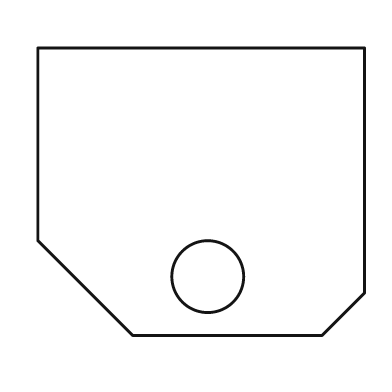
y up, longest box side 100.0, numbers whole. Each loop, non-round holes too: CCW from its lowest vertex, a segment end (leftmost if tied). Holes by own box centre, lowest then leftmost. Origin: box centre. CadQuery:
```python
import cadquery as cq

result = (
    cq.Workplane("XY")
    .moveTo(-21.0, -44.0)
    .lineTo(37.0, -44.0)
    .lineTo(50.0, -31.0)
    .lineTo(50.0, 44.0)
    .lineTo(-50.0, 44.0)
    .lineTo(-50.0, -15.0)
    .close()
    .moveTo(2.0, -26.0)
    .circle(11.0)
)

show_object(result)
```